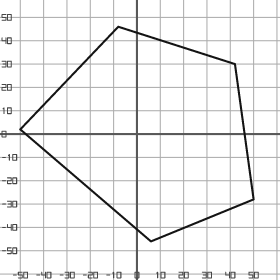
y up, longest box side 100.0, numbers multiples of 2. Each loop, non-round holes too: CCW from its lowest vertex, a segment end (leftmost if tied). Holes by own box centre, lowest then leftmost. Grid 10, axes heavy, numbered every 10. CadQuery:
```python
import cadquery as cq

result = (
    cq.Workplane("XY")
    .moveTo(6.0, -46.0)
    .lineTo(50.0, -28.0)
    .lineTo(42.0, 30.0)
    .lineTo(-8.0, 46.0)
    .lineTo(-50.0, 2.0)
    .close()
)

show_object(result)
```